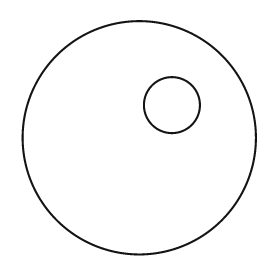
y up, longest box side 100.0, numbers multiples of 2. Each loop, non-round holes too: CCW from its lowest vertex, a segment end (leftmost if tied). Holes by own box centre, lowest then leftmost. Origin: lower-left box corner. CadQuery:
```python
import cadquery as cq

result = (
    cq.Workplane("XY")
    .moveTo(50.0, 50.0)
    .circle(50.0)
    .moveTo(64.0, 64.0)
    .circle(12.0)
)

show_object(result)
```